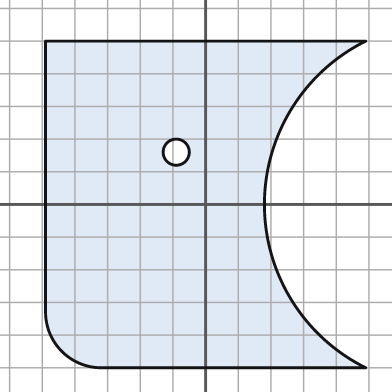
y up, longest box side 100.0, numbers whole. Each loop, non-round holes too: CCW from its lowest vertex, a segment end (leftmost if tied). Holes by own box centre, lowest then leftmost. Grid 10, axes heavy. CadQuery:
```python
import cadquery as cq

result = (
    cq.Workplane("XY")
    .moveTo(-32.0, -50.0)
    .lineTo(49.0, -50.0)
    .threePointArc((18.0, 0.0), (49.0, 50.0))
    .lineTo(-49.0, 50.0)
    .lineTo(-49.0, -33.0)
    .threePointArc((-44.0, -45.0), (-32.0, -50.0))
    .close()
    .moveTo(-9.0, 16.0)
    .circle(4.0)
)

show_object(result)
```